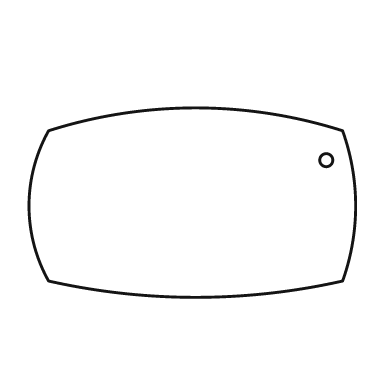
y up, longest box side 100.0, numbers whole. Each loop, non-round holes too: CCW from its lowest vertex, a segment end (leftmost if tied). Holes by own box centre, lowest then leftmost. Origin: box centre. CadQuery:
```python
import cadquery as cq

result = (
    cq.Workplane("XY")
    .moveTo(-44.0, -24.0)
    .threePointArc((1.0, -29.0), (46.0, -24.0))
    .threePointArc((50.0, -1.0), (46.0, 22.0))
    .threePointArc((1.0, 29.0), (-44.0, 22.0))
    .threePointArc((-50.0, -1.0), (-44.0, -24.0))
    .close()
    .moveTo(41.0, 13.0)
    .circle(2.0)
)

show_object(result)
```